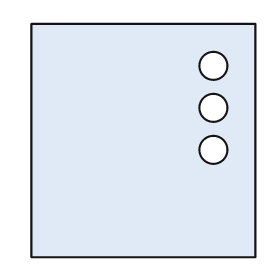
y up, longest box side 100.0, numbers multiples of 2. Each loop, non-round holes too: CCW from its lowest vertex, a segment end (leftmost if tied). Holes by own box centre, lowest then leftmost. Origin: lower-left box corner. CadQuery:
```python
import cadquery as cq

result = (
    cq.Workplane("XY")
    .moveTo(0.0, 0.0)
    .lineTo(96.0, 0.0)
    .lineTo(96.0, 100.0)
    .lineTo(0.0, 100.0)
    .close()
    .moveTo(78.0, 46.0)
    .circle(6.0)
    .moveTo(78.0, 64.0)
    .circle(6.0)
    .moveTo(78.0, 82.0)
    .circle(6.0)
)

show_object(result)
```